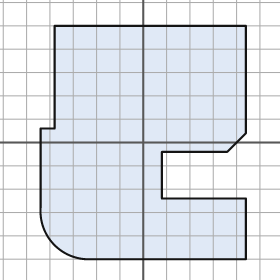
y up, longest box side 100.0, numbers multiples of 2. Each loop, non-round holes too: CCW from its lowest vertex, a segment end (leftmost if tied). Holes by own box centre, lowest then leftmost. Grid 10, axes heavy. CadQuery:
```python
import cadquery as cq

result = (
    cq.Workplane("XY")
    .moveTo(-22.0, -50.0)
    .lineTo(44.0, -50.0)
    .lineTo(44.0, -24.0)
    .lineTo(8.0, -24.0)
    .lineTo(8.0, -4.0)
    .lineTo(36.0, -4.0)
    .lineTo(44.0, 4.0)
    .lineTo(44.0, 50.0)
    .lineTo(-38.0, 50.0)
    .lineTo(-38.0, 6.0)
    .lineTo(-44.0, 6.0)
    .lineTo(-44.0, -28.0)
    .threePointArc((-38.0, -44.0), (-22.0, -50.0))
    .close()
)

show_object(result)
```